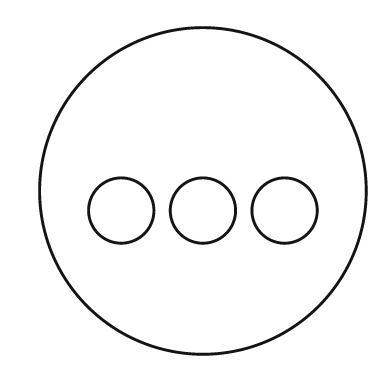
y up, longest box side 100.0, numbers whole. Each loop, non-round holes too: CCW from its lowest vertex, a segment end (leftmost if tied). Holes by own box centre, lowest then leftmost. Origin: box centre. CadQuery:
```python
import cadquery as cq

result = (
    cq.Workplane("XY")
    .moveTo(0.0, 0.0)
    .circle(50.0)
    .moveTo(-25.0, -6.0)
    .circle(10.0)
    .moveTo(0.0, -6.0)
    .circle(10.0)
    .moveTo(25.0, -6.0)
    .circle(10.0)
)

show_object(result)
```